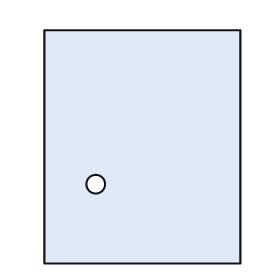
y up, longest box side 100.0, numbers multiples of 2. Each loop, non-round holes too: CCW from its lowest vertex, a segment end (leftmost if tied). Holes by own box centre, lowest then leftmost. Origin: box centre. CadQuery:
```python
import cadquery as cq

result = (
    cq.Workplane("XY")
    .moveTo(-42.0, -50.0)
    .lineTo(42.0, -50.0)
    .lineTo(42.0, 50.0)
    .lineTo(-42.0, 50.0)
    .close()
    .moveTo(-20.0, -16.0)
    .circle(4.0)
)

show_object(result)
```